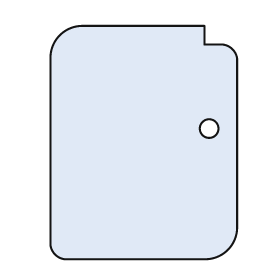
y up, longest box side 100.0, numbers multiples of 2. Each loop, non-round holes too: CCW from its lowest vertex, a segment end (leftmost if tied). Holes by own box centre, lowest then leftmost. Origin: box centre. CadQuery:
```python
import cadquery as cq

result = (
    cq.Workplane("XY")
    .moveTo(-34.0, -50.0)
    .lineTo(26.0, -50.0)
    .threePointArc((36.0, -46.0), (40.0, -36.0))
    .lineTo(40.0, 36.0)
    .threePointArc((38.0, 40.0), (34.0, 42.0))
    .lineTo(26.0, 42.0)
    .lineTo(26.0, 50.0)
    .lineTo(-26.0, 50.0)
    .threePointArc((-36.0, 46.0), (-40.0, 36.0))
    .lineTo(-40.0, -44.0)
    .threePointArc((-38.0, -48.0), (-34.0, -50.0))
    .close()
    .moveTo(28.0, 6.0)
    .circle(4.0)
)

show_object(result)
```